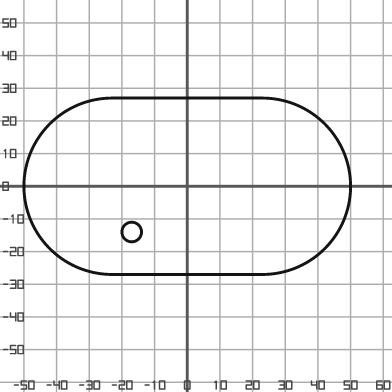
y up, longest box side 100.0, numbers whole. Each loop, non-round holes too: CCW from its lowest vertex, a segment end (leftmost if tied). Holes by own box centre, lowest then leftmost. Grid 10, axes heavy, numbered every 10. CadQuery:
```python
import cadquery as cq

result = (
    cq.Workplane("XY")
    .moveTo(-23.0, -27.0)
    .lineTo(23.0, -27.0)
    .threePointArc((50.0, 0.0), (23.0, 27.0))
    .lineTo(-23.0, 27.0)
    .threePointArc((-50.0, 0.0), (-23.0, -27.0))
    .close()
    .moveTo(-17.0, -14.0)
    .circle(3.0)
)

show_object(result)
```